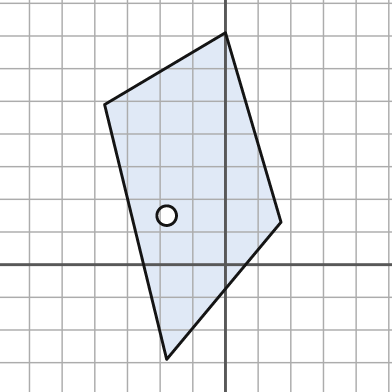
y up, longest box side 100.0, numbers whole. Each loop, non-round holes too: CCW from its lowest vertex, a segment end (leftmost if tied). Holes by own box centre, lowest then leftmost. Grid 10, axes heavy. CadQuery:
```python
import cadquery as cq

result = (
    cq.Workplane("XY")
    .moveTo(-18.0, -29.0)
    .lineTo(17.0, 13.0)
    .lineTo(0.0, 71.0)
    .lineTo(-37.0, 49.0)
    .close()
    .moveTo(-18.0, 15.0)
    .circle(3.0)
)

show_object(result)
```